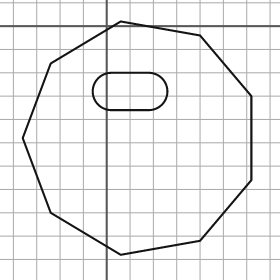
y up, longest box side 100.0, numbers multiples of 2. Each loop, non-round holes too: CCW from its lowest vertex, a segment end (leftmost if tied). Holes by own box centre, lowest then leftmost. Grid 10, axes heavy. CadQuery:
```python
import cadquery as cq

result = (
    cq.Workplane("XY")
    .moveTo(6.0, -98.0)
    .lineTo(40.0, -92.0)
    .lineTo(62.0, -66.0)
    .lineTo(62.0, -30.0)
    .lineTo(40.0, -4.0)
    .lineTo(6.0, 2.0)
    .lineTo(-24.0, -16.0)
    .lineTo(-36.0, -48.0)
    .lineTo(-24.0, -80.0)
    .close()
    .moveTo(2.0, -36.0)
    .lineTo(18.0, -36.0)
    .threePointArc((26.0, -28.0), (18.0, -20.0))
    .lineTo(2.0, -20.0)
    .threePointArc((-6.0, -28.0), (2.0, -36.0))
    .close()
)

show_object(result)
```